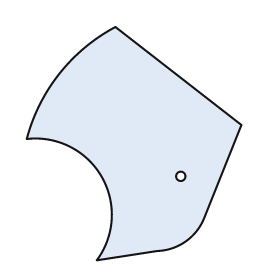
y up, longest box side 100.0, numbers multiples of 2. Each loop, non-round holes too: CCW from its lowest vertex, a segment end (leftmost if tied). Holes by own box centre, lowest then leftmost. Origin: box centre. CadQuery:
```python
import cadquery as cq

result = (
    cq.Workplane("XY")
    .moveTo(-16.0, -50.0)
    .lineTo(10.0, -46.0)
    .threePointArc((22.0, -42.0), (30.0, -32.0))
    .lineTo(46.0, 8.0)
    .lineTo(-8.0, 50.0)
    .threePointArc((-32.0, 30.0), (-46.0, 2.0))
    .threePointArc((-14.0, -14.0), (-16.0, -50.0))
    .close()
    .moveTo(20.0, -14.0)
    .circle(2.0)
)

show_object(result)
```